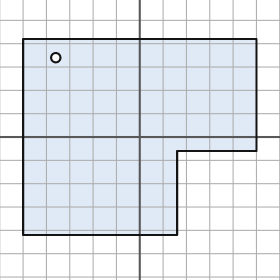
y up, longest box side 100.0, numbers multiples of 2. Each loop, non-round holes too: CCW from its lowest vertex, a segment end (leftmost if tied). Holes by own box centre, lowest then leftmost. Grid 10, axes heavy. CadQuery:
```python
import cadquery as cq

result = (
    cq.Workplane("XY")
    .moveTo(-50.0, -42.0)
    .lineTo(16.0, -42.0)
    .lineTo(16.0, -6.0)
    .lineTo(50.0, -6.0)
    .lineTo(50.0, 42.0)
    .lineTo(-50.0, 42.0)
    .close()
    .moveTo(-36.0, 34.0)
    .circle(2.0)
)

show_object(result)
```